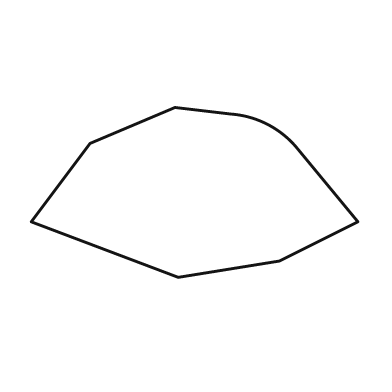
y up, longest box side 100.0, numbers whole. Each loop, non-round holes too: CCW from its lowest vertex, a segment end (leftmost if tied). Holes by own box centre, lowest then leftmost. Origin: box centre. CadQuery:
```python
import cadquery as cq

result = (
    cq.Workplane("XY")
    .moveTo(-5.0, -26.0)
    .lineTo(26.0, -21.0)
    .lineTo(50.0, -9.0)
    .lineTo(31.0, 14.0)
    .threePointArc((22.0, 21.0), (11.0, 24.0))
    .lineTo(-6.0, 26.0)
    .lineTo(-32.0, 15.0)
    .lineTo(-50.0, -9.0)
    .close()
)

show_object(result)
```